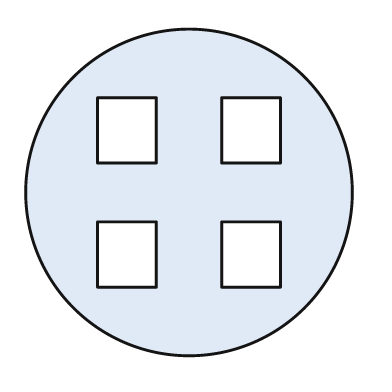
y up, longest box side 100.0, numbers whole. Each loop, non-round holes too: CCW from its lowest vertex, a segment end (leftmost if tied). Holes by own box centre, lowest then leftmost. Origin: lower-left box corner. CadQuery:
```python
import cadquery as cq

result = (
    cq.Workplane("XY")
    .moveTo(50.0, 50.0)
    .circle(50.0)
    .moveTo(22.0, 21.0)
    .lineTo(40.0, 21.0)
    .lineTo(40.0, 41.0)
    .lineTo(22.0, 41.0)
    .close()
    .moveTo(60.0, 21.0)
    .lineTo(78.0, 21.0)
    .lineTo(78.0, 41.0)
    .lineTo(60.0, 41.0)
    .close()
    .moveTo(22.0, 59.0)
    .lineTo(40.0, 59.0)
    .lineTo(40.0, 79.0)
    .lineTo(22.0, 79.0)
    .close()
    .moveTo(60.0, 59.0)
    .lineTo(78.0, 59.0)
    .lineTo(78.0, 79.0)
    .lineTo(60.0, 79.0)
    .close()
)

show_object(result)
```